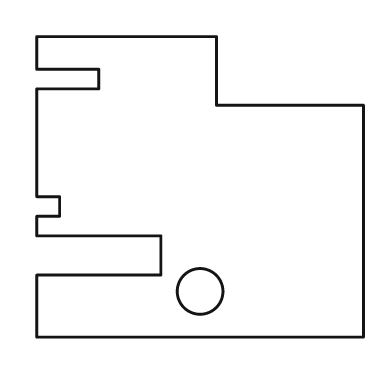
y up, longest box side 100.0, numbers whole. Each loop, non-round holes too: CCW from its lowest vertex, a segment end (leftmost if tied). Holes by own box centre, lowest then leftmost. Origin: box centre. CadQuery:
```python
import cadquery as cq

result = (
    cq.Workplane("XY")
    .moveTo(-50.0, -46.0)
    .lineTo(50.0, -46.0)
    .lineTo(50.0, 25.0)
    .lineTo(5.0, 25.0)
    .lineTo(5.0, 46.0)
    .lineTo(-50.0, 46.0)
    .lineTo(-50.0, 36.0)
    .lineTo(-31.0, 36.0)
    .lineTo(-31.0, 30.0)
    .lineTo(-50.0, 30.0)
    .lineTo(-50.0, -3.0)
    .lineTo(-43.0, -3.0)
    .lineTo(-43.0, -9.0)
    .lineTo(-50.0, -9.0)
    .lineTo(-50.0, -15.0)
    .lineTo(-12.0, -15.0)
    .lineTo(-12.0, -27.0)
    .lineTo(-50.0, -27.0)
    .close()
    .moveTo(0.0, -32.0)
    .circle(7.0)
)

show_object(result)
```